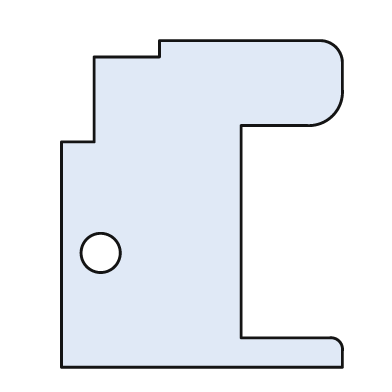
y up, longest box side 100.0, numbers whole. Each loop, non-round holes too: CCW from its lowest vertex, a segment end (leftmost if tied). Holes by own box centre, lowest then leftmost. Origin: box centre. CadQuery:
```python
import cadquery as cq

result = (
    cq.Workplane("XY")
    .moveTo(-43.0, -50.0)
    .lineTo(43.0, -50.0)
    .lineTo(43.0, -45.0)
    .threePointArc((42.0, -42.0), (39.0, -41.0))
    .lineTo(12.0, -41.0)
    .lineTo(12.0, 24.0)
    .lineTo(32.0, 24.0)
    .threePointArc((40.0, 27.0), (43.0, 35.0))
    .lineTo(43.0, 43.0)
    .threePointArc((41.0, 48.0), (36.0, 50.0))
    .lineTo(-13.0, 50.0)
    .lineTo(-13.0, 45.0)
    .lineTo(-33.0, 45.0)
    .lineTo(-33.0, 19.0)
    .lineTo(-43.0, 19.0)
    .close()
    .moveTo(-31.0, -15.0)
    .circle(6.0)
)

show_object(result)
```